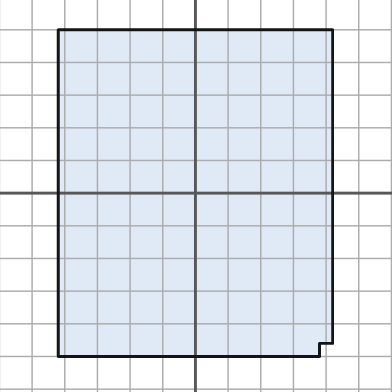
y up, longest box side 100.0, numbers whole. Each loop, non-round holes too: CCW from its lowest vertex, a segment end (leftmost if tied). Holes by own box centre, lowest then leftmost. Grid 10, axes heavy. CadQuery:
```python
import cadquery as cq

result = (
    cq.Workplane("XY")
    .moveTo(-42.0, -50.0)
    .lineTo(38.0, -50.0)
    .lineTo(38.0, -46.0)
    .lineTo(42.0, -46.0)
    .lineTo(42.0, 50.0)
    .lineTo(-42.0, 50.0)
    .close()
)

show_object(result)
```